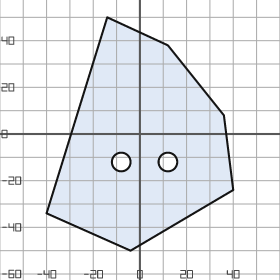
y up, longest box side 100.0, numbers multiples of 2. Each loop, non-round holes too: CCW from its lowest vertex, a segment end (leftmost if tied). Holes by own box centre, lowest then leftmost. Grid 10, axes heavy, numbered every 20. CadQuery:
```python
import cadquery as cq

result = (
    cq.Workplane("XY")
    .moveTo(-4.0, -50.0)
    .lineTo(40.0, -24.0)
    .lineTo(36.0, 8.0)
    .lineTo(12.0, 38.0)
    .lineTo(-14.0, 50.0)
    .lineTo(-40.0, -34.0)
    .close()
    .moveTo(-8.0, -12.0)
    .circle(4.0)
    .moveTo(12.0, -12.0)
    .circle(4.0)
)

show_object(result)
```